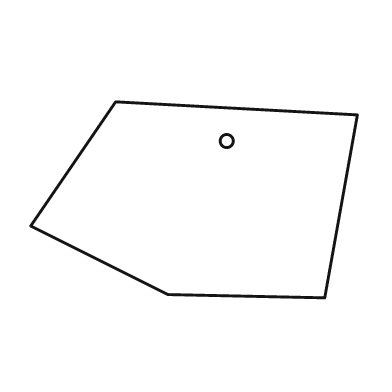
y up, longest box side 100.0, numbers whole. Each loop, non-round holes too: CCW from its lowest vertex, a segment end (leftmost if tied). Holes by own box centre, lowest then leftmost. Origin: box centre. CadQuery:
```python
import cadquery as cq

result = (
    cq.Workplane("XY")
    .moveTo(40.0, -30.0)
    .lineTo(50.0, 26.0)
    .lineTo(-24.0, 30.0)
    .lineTo(-50.0, -8.0)
    .lineTo(-8.0, -29.0)
    .close()
    .moveTo(10.0, 18.0)
    .circle(2.0)
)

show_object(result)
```